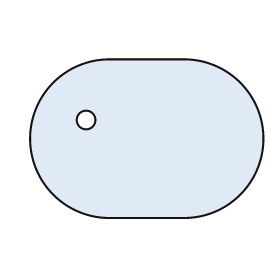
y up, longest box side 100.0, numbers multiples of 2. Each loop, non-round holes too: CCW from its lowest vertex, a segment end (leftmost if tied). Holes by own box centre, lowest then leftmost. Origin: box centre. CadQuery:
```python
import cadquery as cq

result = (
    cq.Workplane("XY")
    .moveTo(-16.0, -34.0)
    .lineTo(16.0, -34.0)
    .threePointArc((50.0, 0.0), (16.0, 34.0))
    .lineTo(-16.0, 34.0)
    .threePointArc((-50.0, 0.0), (-16.0, -34.0))
    .close()
    .moveTo(-26.0, 8.0)
    .circle(4.0)
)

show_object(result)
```